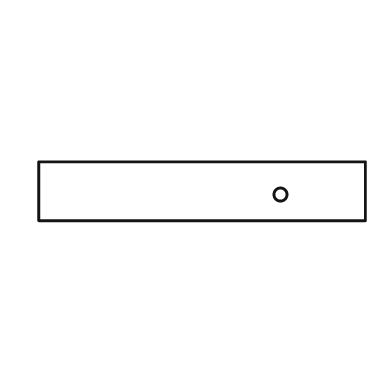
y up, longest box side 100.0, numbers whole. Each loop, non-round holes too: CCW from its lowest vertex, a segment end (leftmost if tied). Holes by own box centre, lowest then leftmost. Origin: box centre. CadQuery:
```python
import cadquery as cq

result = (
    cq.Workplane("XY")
    .moveTo(-50.0, -9.0)
    .lineTo(50.0, -9.0)
    .lineTo(50.0, 9.0)
    .lineTo(-50.0, 9.0)
    .close()
    .moveTo(24.0, -1.0)
    .circle(2.0)
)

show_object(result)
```